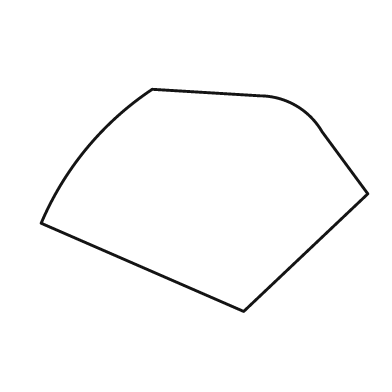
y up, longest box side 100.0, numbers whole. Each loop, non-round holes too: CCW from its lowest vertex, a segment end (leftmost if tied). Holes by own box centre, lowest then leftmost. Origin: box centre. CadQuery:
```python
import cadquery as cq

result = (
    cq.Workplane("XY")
    .moveTo(12.0, -34.0)
    .lineTo(50.0, 2.0)
    .lineTo(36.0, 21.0)
    .threePointArc((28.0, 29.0), (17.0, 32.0))
    .lineTo(-16.0, 34.0)
    .threePointArc((-36.0, 16.0), (-50.0, -7.0))
    .close()
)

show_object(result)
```